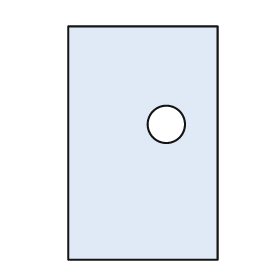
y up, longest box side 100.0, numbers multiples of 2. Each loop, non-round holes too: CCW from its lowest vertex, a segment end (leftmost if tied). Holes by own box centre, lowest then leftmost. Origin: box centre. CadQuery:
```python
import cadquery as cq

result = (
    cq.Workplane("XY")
    .moveTo(-32.0, -50.0)
    .lineTo(32.0, -50.0)
    .lineTo(32.0, 50.0)
    .lineTo(-32.0, 50.0)
    .close()
    .moveTo(10.0, 8.0)
    .circle(8.0)
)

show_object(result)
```